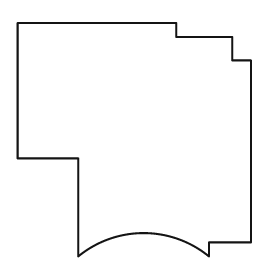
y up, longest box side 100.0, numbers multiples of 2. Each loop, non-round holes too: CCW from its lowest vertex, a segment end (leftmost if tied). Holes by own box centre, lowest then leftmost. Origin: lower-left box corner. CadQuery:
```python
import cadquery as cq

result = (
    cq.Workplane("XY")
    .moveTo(26.0, 0.0)
    .threePointArc((54.0, 10.0), (82.0, 0.0))
    .lineTo(82.0, 6.0)
    .lineTo(100.0, 6.0)
    .lineTo(100.0, 84.0)
    .lineTo(92.0, 84.0)
    .lineTo(92.0, 94.0)
    .lineTo(68.0, 94.0)
    .lineTo(68.0, 100.0)
    .lineTo(0.0, 100.0)
    .lineTo(0.0, 42.0)
    .lineTo(26.0, 42.0)
    .close()
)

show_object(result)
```